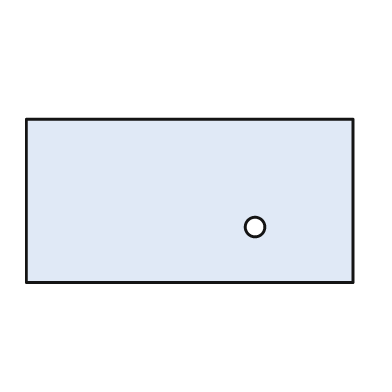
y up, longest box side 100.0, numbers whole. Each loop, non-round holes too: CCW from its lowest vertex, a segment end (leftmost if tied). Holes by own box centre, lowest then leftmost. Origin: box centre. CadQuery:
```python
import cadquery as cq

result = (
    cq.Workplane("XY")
    .moveTo(-50.0, -25.0)
    .lineTo(50.0, -25.0)
    .lineTo(50.0, 25.0)
    .lineTo(-50.0, 25.0)
    .close()
    .moveTo(20.0, -8.0)
    .circle(3.0)
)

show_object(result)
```